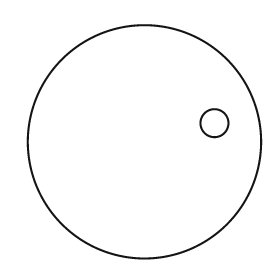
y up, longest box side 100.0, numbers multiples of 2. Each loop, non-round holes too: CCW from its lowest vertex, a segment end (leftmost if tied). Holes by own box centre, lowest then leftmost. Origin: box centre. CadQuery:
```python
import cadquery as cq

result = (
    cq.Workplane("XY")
    .moveTo(0.0, 0.0)
    .circle(50.0)
    .moveTo(30.0, 8.0)
    .circle(6.0)
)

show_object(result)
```